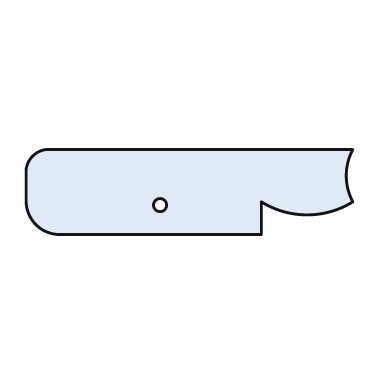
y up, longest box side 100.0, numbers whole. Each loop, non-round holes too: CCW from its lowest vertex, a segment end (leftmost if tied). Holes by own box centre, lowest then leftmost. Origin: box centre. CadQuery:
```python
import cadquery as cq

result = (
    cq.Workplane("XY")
    .moveTo(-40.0, -13.0)
    .lineTo(22.0, -13.0)
    .lineTo(22.0, -3.0)
    .threePointArc((36.0, -7.0), (50.0, -3.0))
    .threePointArc((48.0, 5.0), (50.0, 13.0))
    .lineTo(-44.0, 13.0)
    .threePointArc((-48.0, 11.0), (-50.0, 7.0))
    .lineTo(-50.0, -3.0)
    .threePointArc((-47.0, -10.0), (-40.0, -13.0))
    .close()
    .moveTo(-9.0, -4.0)
    .circle(2.0)
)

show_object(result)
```